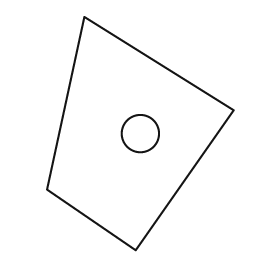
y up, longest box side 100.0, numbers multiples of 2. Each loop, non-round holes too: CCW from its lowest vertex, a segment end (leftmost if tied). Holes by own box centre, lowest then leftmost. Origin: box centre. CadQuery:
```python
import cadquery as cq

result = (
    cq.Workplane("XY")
    .moveTo(-2.0, -50.0)
    .lineTo(40.0, 10.0)
    .lineTo(-24.0, 50.0)
    .lineTo(-40.0, -24.0)
    .close()
    .moveTo(0.0, 0.0)
    .circle(8.0)
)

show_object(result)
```